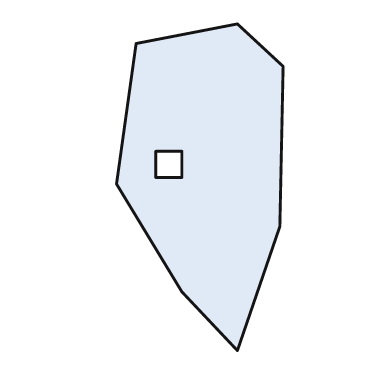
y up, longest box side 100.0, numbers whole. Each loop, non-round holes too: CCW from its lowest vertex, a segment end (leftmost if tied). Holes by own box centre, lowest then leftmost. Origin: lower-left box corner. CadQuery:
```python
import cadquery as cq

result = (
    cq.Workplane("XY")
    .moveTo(37.0, 0.0)
    .lineTo(50.0, 38.0)
    .lineTo(51.0, 87.0)
    .lineTo(37.0, 100.0)
    .lineTo(6.0, 94.0)
    .lineTo(0.0, 51.0)
    .lineTo(20.0, 18.0)
    .close()
    .moveTo(12.0, 53.0)
    .lineTo(20.0, 53.0)
    .lineTo(20.0, 61.0)
    .lineTo(12.0, 61.0)
    .close()
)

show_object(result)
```